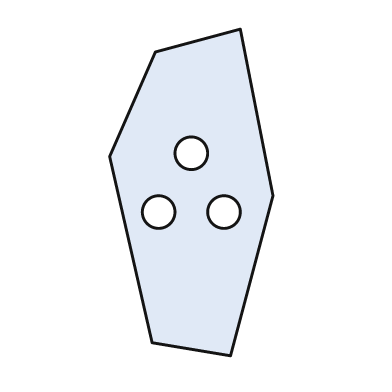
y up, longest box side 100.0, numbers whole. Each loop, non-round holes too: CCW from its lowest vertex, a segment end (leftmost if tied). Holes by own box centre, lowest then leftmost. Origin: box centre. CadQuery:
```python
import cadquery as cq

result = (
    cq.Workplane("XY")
    .moveTo(12.0, -50.0)
    .lineTo(25.0, -1.0)
    .lineTo(15.0, 50.0)
    .lineTo(-11.0, 43.0)
    .lineTo(-25.0, 11.0)
    .lineTo(-12.0, -46.0)
    .close()
    .moveTo(-10.0, -6.0)
    .circle(5.0)
    .moveTo(10.0, -6.0)
    .circle(5.0)
    .moveTo(0.0, 12.0)
    .circle(5.0)
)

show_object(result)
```